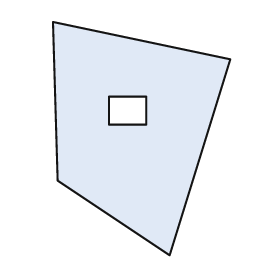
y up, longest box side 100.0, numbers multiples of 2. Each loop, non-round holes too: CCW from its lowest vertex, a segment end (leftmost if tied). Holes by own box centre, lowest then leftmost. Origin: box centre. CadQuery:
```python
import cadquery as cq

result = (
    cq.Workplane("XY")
    .moveTo(12.0, -50.0)
    .lineTo(38.0, 34.0)
    .lineTo(-38.0, 50.0)
    .lineTo(-36.0, -18.0)
    .close()
    .moveTo(-14.0, 6.0)
    .lineTo(2.0, 6.0)
    .lineTo(2.0, 18.0)
    .lineTo(-14.0, 18.0)
    .close()
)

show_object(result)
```